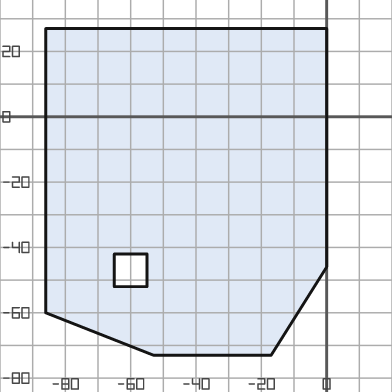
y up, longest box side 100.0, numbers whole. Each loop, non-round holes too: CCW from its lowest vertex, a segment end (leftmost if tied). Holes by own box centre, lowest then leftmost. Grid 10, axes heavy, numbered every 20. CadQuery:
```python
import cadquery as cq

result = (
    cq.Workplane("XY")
    .moveTo(-53.0, -73.0)
    .lineTo(-17.0, -73.0)
    .lineTo(0.0, -46.0)
    .lineTo(0.0, 27.0)
    .lineTo(-86.0, 27.0)
    .lineTo(-86.0, -60.0)
    .close()
    .moveTo(-65.0, -52.0)
    .lineTo(-55.0, -52.0)
    .lineTo(-55.0, -42.0)
    .lineTo(-65.0, -42.0)
    .close()
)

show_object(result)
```